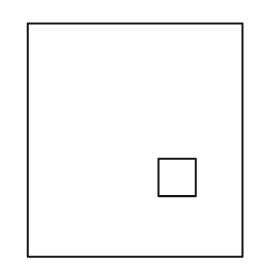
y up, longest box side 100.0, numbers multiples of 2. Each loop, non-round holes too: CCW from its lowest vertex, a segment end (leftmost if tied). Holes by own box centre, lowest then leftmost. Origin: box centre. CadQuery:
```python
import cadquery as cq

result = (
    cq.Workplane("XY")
    .moveTo(-46.0, -50.0)
    .lineTo(46.0, -50.0)
    .lineTo(46.0, 50.0)
    .lineTo(-46.0, 50.0)
    .close()
    .moveTo(10.0, -24.0)
    .lineTo(26.0, -24.0)
    .lineTo(26.0, -8.0)
    .lineTo(10.0, -8.0)
    .close()
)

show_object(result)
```